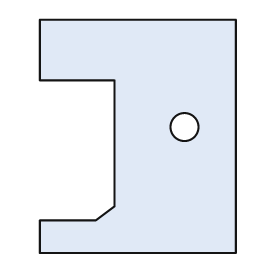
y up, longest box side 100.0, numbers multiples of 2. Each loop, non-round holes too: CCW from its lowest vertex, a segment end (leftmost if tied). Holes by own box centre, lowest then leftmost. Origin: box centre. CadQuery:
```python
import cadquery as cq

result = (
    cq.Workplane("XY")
    .moveTo(-42.0, -50.0)
    .lineTo(42.0, -50.0)
    .lineTo(42.0, 50.0)
    .lineTo(-42.0, 50.0)
    .lineTo(-42.0, 24.0)
    .lineTo(-10.0, 24.0)
    .lineTo(-10.0, -30.0)
    .lineTo(-18.0, -36.0)
    .lineTo(-42.0, -36.0)
    .close()
    .moveTo(20.0, 4.0)
    .circle(6.0)
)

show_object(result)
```